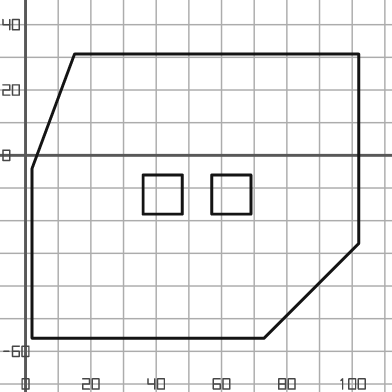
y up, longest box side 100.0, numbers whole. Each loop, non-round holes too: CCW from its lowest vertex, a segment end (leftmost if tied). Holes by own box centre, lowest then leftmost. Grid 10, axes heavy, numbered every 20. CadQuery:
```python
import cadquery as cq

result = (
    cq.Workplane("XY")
    .moveTo(2.0, -56.0)
    .lineTo(73.0, -56.0)
    .lineTo(102.0, -27.0)
    .lineTo(102.0, 31.0)
    .lineTo(15.0, 31.0)
    .lineTo(2.0, -4.0)
    .close()
    .moveTo(36.0, -18.0)
    .lineTo(48.0, -18.0)
    .lineTo(48.0, -6.0)
    .lineTo(36.0, -6.0)
    .close()
    .moveTo(57.0, -18.0)
    .lineTo(69.0, -18.0)
    .lineTo(69.0, -6.0)
    .lineTo(57.0, -6.0)
    .close()
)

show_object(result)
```